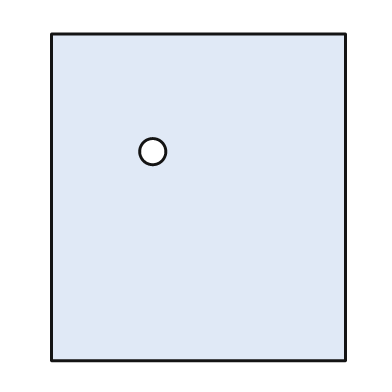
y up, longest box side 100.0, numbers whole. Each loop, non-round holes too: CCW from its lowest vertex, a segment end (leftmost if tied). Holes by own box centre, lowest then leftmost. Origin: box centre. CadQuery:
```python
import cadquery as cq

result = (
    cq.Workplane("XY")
    .moveTo(-45.0, -50.0)
    .lineTo(45.0, -50.0)
    .lineTo(45.0, 50.0)
    .lineTo(-45.0, 50.0)
    .close()
    .moveTo(-14.0, 14.0)
    .circle(4.0)
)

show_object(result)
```